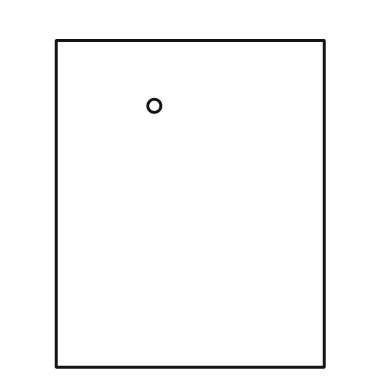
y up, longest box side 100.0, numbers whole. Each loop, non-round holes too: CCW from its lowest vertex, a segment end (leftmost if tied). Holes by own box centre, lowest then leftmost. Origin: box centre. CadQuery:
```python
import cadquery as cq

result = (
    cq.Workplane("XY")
    .moveTo(-41.0, -50.0)
    .lineTo(41.0, -50.0)
    .lineTo(41.0, 50.0)
    .lineTo(-41.0, 50.0)
    .close()
    .moveTo(-11.0, 30.0)
    .circle(2.0)
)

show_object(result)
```